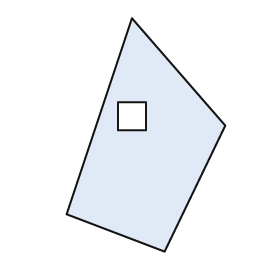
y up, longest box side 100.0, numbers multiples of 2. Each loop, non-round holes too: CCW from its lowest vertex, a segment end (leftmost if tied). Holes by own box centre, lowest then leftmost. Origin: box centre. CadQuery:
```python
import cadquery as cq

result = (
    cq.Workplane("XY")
    .moveTo(8.0, -50.0)
    .lineTo(34.0, 4.0)
    .lineTo(-6.0, 50.0)
    .lineTo(-34.0, -34.0)
    .close()
    .moveTo(-12.0, 2.0)
    .lineTo(0.0, 2.0)
    .lineTo(0.0, 14.0)
    .lineTo(-12.0, 14.0)
    .close()
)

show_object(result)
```